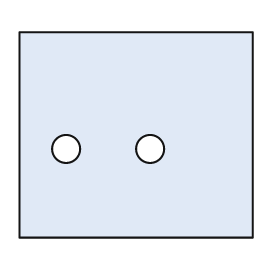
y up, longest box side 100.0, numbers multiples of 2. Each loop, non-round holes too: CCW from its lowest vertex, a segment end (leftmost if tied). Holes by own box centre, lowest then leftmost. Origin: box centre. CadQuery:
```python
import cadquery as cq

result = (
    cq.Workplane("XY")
    .moveTo(-50.0, -44.0)
    .lineTo(50.0, -44.0)
    .lineTo(50.0, 44.0)
    .lineTo(-50.0, 44.0)
    .close()
    .moveTo(-30.0, -6.0)
    .circle(6.0)
    .moveTo(6.0, -6.0)
    .circle(6.0)
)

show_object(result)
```